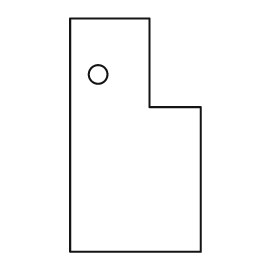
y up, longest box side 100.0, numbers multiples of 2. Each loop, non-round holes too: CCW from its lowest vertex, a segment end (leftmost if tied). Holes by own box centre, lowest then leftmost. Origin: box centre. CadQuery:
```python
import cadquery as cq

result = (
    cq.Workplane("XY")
    .moveTo(-28.0, -50.0)
    .lineTo(28.0, -50.0)
    .lineTo(28.0, 12.0)
    .lineTo(6.0, 12.0)
    .lineTo(6.0, 50.0)
    .lineTo(-28.0, 50.0)
    .close()
    .moveTo(-16.0, 26.0)
    .circle(4.0)
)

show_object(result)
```